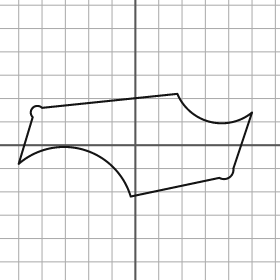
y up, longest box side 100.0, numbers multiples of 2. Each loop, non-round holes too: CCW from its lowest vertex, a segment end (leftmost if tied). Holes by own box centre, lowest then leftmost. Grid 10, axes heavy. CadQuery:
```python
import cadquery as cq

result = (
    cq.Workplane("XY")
    .moveTo(-2.0, -22.0)
    .lineTo(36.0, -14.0)
    .threePointArc((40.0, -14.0), (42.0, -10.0))
    .lineTo(50.0, 14.0)
    .threePointArc((32.0, 10.0), (18.0, 22.0))
    .lineTo(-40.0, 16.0)
    .threePointArc((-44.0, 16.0), (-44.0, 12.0))
    .lineTo(-50.0, -8.0)
    .threePointArc((-22.0, -2.0), (-2.0, -22.0))
    .close()
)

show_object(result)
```